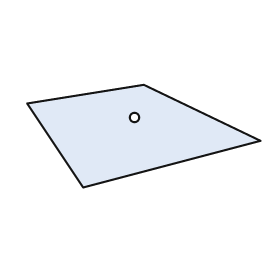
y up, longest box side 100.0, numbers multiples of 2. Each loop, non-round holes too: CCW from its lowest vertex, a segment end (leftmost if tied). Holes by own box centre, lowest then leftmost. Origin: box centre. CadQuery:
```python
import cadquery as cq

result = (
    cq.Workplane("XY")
    .moveTo(-26.0, -22.0)
    .lineTo(50.0, -2.0)
    .lineTo(0.0, 22.0)
    .lineTo(-50.0, 14.0)
    .close()
    .moveTo(-4.0, 8.0)
    .circle(2.0)
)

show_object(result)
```